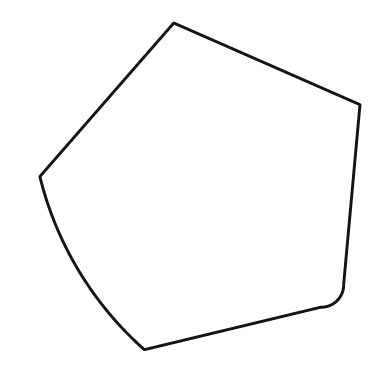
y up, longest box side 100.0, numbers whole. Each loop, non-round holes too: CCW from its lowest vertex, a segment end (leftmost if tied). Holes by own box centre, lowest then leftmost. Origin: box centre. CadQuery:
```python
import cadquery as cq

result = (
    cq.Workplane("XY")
    .moveTo(-17.0, -50.0)
    .lineTo(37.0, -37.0)
    .threePointArc((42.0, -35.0), (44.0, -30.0))
    .lineTo(49.0, 25.0)
    .lineTo(-8.0, 50.0)
    .lineTo(-49.0, 3.0)
    .threePointArc((-37.0, -26.0), (-17.0, -50.0))
    .close()
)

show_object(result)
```